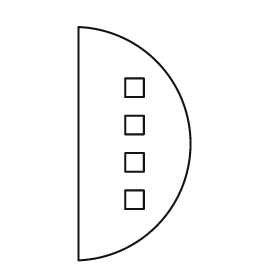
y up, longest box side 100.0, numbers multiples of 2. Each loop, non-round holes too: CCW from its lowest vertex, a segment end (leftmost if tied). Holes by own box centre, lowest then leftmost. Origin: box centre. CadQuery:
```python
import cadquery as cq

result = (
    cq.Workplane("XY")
    .moveTo(-24.0, -50.0)
    .threePointArc((24.0, 0.0), (-24.0, 50.0))
    .close()
    .moveTo(-4.0, -28.0)
    .lineTo(4.0, -28.0)
    .lineTo(4.0, -20.0)
    .lineTo(-4.0, -20.0)
    .close()
    .moveTo(-4.0, -12.0)
    .lineTo(4.0, -12.0)
    .lineTo(4.0, -4.0)
    .lineTo(-4.0, -4.0)
    .close()
    .moveTo(-4.0, 4.0)
    .lineTo(4.0, 4.0)
    .lineTo(4.0, 12.0)
    .lineTo(-4.0, 12.0)
    .close()
    .moveTo(-4.0, 20.0)
    .lineTo(4.0, 20.0)
    .lineTo(4.0, 28.0)
    .lineTo(-4.0, 28.0)
    .close()
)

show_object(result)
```